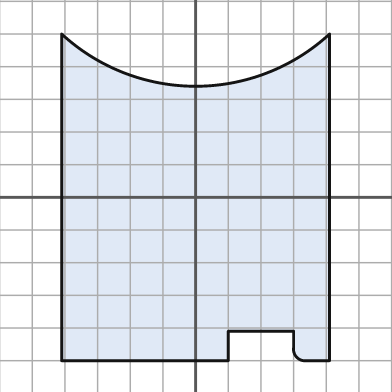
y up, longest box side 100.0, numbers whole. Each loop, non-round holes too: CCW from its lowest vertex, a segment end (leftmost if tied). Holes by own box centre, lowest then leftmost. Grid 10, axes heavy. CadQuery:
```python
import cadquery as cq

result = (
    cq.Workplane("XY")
    .moveTo(-41.0, -50.0)
    .lineTo(10.0, -50.0)
    .lineTo(10.0, -41.0)
    .lineTo(30.0, -41.0)
    .lineTo(30.0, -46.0)
    .threePointArc((31.0, -49.0), (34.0, -50.0))
    .lineTo(41.0, -50.0)
    .lineTo(41.0, 50.0)
    .threePointArc((0.0, 34.0), (-41.0, 50.0))
    .close()
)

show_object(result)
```